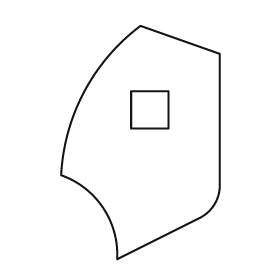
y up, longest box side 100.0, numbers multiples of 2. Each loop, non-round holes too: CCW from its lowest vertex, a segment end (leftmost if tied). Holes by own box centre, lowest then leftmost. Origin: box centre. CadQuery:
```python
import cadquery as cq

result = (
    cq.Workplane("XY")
    .moveTo(-10.0, -50.0)
    .lineTo(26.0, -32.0)
    .threePointArc((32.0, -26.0), (34.0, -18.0))
    .lineTo(34.0, 38.0)
    .lineTo(0.0, 50.0)
    .threePointArc((-24.0, 22.0), (-34.0, -14.0))
    .threePointArc((-16.0, -28.0), (-10.0, -50.0))
    .close()
    .moveTo(-4.0, 6.0)
    .lineTo(12.0, 6.0)
    .lineTo(12.0, 22.0)
    .lineTo(-4.0, 22.0)
    .close()
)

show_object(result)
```